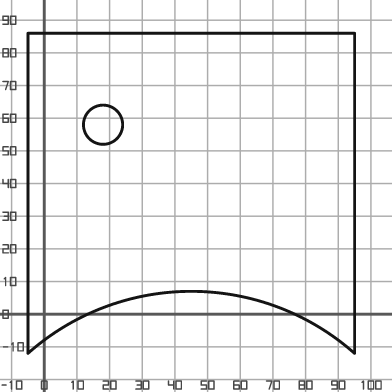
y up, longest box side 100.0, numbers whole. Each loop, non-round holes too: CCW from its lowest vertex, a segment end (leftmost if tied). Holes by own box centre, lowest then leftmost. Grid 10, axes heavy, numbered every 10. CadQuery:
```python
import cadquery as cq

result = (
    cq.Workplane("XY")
    .moveTo(-5.0, -12.0)
    .threePointArc((45.0, 7.0), (95.0, -12.0))
    .lineTo(95.0, 86.0)
    .lineTo(-5.0, 86.0)
    .close()
    .moveTo(18.0, 58.0)
    .circle(6.0)
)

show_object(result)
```